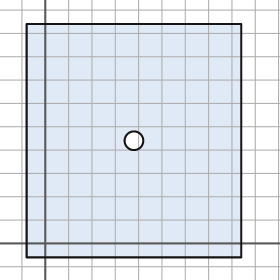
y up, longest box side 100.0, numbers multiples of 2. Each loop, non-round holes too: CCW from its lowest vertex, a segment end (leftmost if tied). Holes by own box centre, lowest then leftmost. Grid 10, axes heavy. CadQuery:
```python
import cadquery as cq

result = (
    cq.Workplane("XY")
    .moveTo(-8.0, -6.0)
    .lineTo(84.0, -6.0)
    .lineTo(84.0, 94.0)
    .lineTo(-8.0, 94.0)
    .close()
    .moveTo(38.0, 44.0)
    .circle(4.0)
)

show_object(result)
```